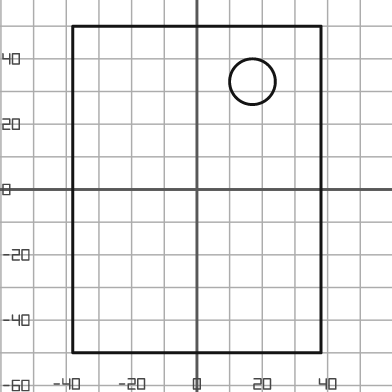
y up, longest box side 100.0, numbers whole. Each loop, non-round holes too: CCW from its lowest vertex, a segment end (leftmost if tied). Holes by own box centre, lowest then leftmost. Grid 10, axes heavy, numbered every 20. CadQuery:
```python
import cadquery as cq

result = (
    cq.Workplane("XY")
    .moveTo(-38.0, -50.0)
    .lineTo(38.0, -50.0)
    .lineTo(38.0, 50.0)
    .lineTo(-38.0, 50.0)
    .close()
    .moveTo(17.0, 33.0)
    .circle(7.0)
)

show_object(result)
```